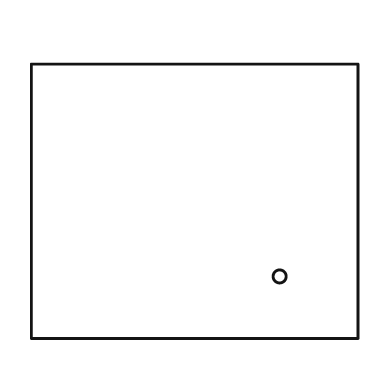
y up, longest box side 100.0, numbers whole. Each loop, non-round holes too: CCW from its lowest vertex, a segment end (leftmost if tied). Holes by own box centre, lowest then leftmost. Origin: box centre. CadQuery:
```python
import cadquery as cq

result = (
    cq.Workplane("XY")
    .moveTo(-50.0, -42.0)
    .lineTo(50.0, -42.0)
    .lineTo(50.0, 42.0)
    .lineTo(-50.0, 42.0)
    .close()
    .moveTo(26.0, -23.0)
    .circle(2.0)
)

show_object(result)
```